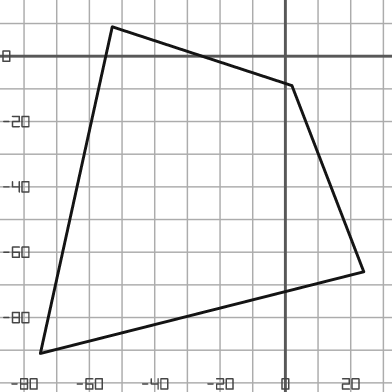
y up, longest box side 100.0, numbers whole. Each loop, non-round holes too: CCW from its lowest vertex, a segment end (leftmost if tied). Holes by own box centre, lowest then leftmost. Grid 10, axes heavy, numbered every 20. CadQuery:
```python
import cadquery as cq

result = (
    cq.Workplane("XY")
    .moveTo(-75.0, -91.0)
    .lineTo(24.0, -66.0)
    .lineTo(2.0, -9.0)
    .lineTo(-53.0, 9.0)
    .close()
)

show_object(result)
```